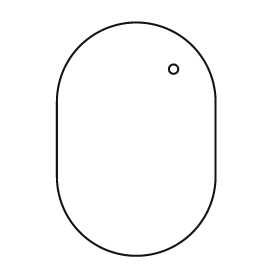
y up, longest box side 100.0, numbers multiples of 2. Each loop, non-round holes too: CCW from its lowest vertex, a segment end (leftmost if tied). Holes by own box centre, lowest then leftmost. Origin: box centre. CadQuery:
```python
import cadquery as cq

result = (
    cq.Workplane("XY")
    .moveTo(-34.0, -16.0)
    .threePointArc((0.0, -50.0), (34.0, -16.0))
    .lineTo(34.0, 16.0)
    .threePointArc((0.0, 50.0), (-34.0, 16.0))
    .close()
    .moveTo(16.0, 30.0)
    .circle(2.0)
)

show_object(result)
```